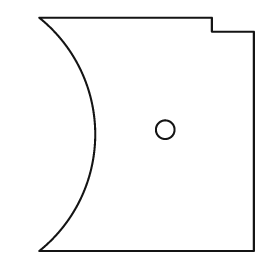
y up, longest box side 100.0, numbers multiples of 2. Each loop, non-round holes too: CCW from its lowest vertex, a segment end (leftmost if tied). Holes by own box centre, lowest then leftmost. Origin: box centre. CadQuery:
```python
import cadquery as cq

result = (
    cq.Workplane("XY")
    .moveTo(-46.0, -50.0)
    .lineTo(46.0, -50.0)
    .lineTo(46.0, 44.0)
    .lineTo(28.0, 44.0)
    .lineTo(28.0, 50.0)
    .lineTo(-46.0, 50.0)
    .threePointArc((-22.0, 0.0), (-46.0, -50.0))
    .close()
    .moveTo(8.0, 2.0)
    .circle(4.0)
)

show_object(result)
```